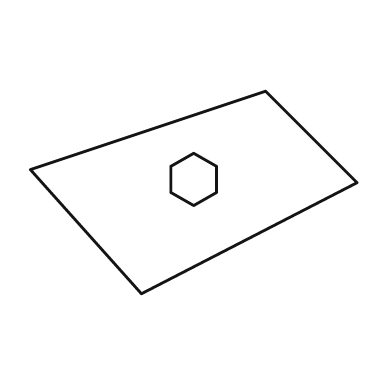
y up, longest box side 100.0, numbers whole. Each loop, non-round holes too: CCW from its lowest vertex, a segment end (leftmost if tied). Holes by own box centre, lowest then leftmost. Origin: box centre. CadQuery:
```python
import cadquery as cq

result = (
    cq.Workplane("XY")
    .moveTo(-16.0, -31.0)
    .lineTo(50.0, 3.0)
    .lineTo(22.0, 31.0)
    .lineTo(-50.0, 7.0)
    .close()
    .moveTo(0.0, -4.0)
    .lineTo(7.0, 0.0)
    .lineTo(7.0, 8.0)
    .lineTo(0.0, 12.0)
    .lineTo(-7.0, 8.0)
    .lineTo(-7.0, 0.0)
    .close()
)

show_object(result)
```